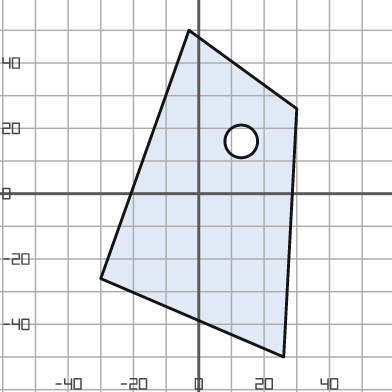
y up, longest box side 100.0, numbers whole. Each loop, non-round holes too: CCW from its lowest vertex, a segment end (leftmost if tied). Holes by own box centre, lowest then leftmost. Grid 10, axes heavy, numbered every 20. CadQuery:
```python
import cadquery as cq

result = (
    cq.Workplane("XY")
    .moveTo(26.0, -50.0)
    .lineTo(30.0, 26.0)
    .lineTo(-3.0, 50.0)
    .lineTo(-30.0, -26.0)
    .close()
    .moveTo(13.0, 16.0)
    .circle(5.0)
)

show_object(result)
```